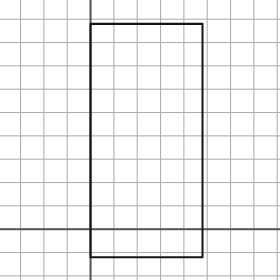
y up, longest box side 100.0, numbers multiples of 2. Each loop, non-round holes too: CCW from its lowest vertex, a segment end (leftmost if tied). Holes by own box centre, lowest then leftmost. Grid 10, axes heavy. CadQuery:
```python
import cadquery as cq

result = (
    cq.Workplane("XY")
    .moveTo(0.0, -12.0)
    .lineTo(48.0, -12.0)
    .lineTo(48.0, 88.0)
    .lineTo(0.0, 88.0)
    .close()
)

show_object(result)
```